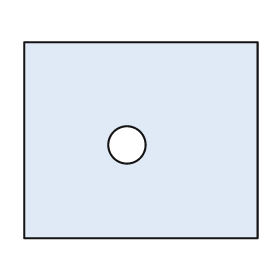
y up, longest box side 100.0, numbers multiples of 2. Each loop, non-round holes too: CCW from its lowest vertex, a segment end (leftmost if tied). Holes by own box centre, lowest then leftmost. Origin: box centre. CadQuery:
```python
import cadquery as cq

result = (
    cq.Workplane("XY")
    .moveTo(-50.0, -42.0)
    .lineTo(50.0, -42.0)
    .lineTo(50.0, 42.0)
    .lineTo(-50.0, 42.0)
    .close()
    .moveTo(-6.0, -2.0)
    .circle(8.0)
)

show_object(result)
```